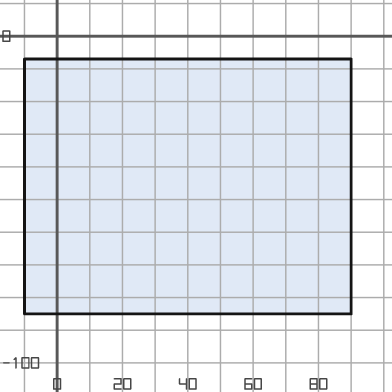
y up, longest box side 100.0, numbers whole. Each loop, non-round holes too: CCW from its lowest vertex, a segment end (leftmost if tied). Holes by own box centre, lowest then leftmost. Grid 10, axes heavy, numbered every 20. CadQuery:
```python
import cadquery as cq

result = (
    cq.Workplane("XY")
    .moveTo(-10.0, -85.0)
    .lineTo(90.0, -85.0)
    .lineTo(90.0, -7.0)
    .lineTo(-10.0, -7.0)
    .close()
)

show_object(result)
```